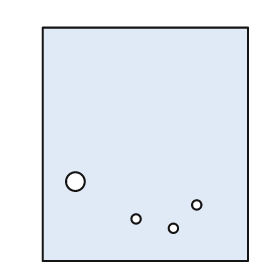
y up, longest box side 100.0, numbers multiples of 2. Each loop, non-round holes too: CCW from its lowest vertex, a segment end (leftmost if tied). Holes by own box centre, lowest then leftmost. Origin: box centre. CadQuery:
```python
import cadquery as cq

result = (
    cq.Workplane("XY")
    .moveTo(-44.0, -50.0)
    .lineTo(44.0, -50.0)
    .lineTo(44.0, 50.0)
    .lineTo(-44.0, 50.0)
    .close()
    .moveTo(12.0, -36.0)
    .circle(2.0)
    .moveTo(-4.0, -32.0)
    .circle(2.0)
    .moveTo(22.0, -26.0)
    .circle(2.0)
    .moveTo(-30.0, -16.0)
    .circle(4.0)
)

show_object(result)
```